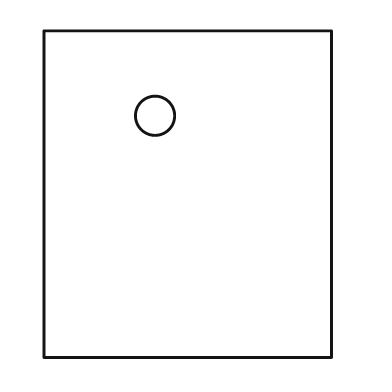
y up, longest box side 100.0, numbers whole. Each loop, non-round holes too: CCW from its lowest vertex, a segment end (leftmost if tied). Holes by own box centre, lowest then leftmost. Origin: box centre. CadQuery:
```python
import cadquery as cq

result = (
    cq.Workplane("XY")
    .moveTo(-44.0, -50.0)
    .lineTo(44.0, -50.0)
    .lineTo(44.0, 50.0)
    .lineTo(-44.0, 50.0)
    .close()
    .moveTo(-10.0, 24.0)
    .circle(6.0)
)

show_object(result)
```